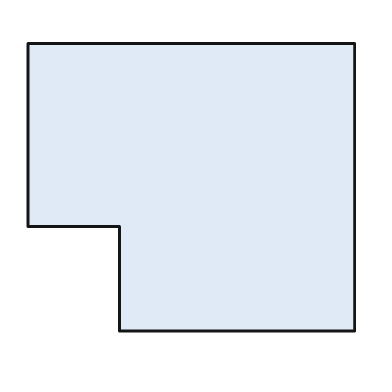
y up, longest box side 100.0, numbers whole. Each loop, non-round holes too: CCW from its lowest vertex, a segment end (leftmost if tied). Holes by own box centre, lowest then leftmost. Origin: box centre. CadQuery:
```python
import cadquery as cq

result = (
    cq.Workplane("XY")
    .moveTo(-22.0, -44.0)
    .lineTo(50.0, -44.0)
    .lineTo(50.0, 44.0)
    .lineTo(-50.0, 44.0)
    .lineTo(-50.0, -12.0)
    .lineTo(-22.0, -12.0)
    .close()
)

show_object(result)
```